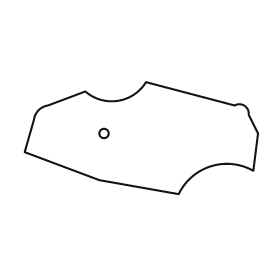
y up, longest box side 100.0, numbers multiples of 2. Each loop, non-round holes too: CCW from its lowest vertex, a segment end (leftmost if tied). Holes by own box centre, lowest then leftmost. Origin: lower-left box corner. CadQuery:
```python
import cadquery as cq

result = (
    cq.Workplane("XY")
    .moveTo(66.0, 0.0)
    .threePointArc((80.0, 12.0), (98.0, 10.0))
    .lineTo(100.0, 26.0)
    .lineTo(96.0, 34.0)
    .threePointArc((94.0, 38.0), (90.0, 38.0))
    .lineTo(52.0, 48.0)
    .threePointArc((40.0, 40.0), (26.0, 44.0))
    .lineTo(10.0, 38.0)
    .threePointArc((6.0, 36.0), (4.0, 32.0))
    .lineTo(0.0, 18.0)
    .lineTo(32.0, 6.0)
    .close()
    .moveTo(34.0, 26.0)
    .circle(2.0)
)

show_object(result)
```